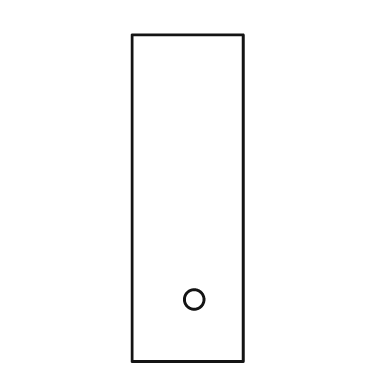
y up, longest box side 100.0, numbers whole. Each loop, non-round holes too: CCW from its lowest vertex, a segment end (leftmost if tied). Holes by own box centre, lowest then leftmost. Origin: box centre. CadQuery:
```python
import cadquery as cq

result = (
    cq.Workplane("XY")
    .moveTo(-17.0, -50.0)
    .lineTo(17.0, -50.0)
    .lineTo(17.0, 50.0)
    .lineTo(-17.0, 50.0)
    .close()
    .moveTo(2.0, -31.0)
    .circle(3.0)
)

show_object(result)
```